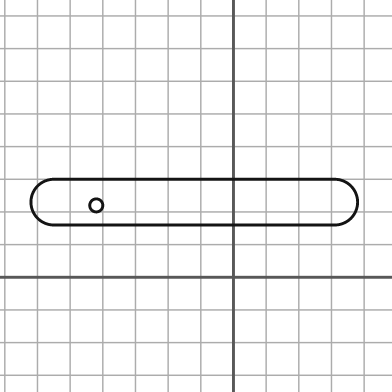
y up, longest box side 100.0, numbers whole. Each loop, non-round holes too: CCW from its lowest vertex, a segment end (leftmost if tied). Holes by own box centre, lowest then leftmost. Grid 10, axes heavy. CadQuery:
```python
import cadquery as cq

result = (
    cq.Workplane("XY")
    .moveTo(-55.0, 16.0)
    .lineTo(31.0, 16.0)
    .threePointArc((38.0, 23.0), (31.0, 30.0))
    .lineTo(-55.0, 30.0)
    .threePointArc((-62.0, 23.0), (-55.0, 16.0))
    .close()
    .moveTo(-42.0, 22.0)
    .circle(2.0)
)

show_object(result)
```